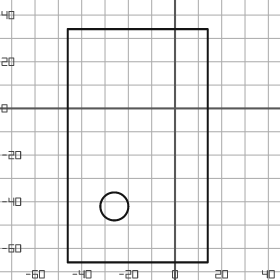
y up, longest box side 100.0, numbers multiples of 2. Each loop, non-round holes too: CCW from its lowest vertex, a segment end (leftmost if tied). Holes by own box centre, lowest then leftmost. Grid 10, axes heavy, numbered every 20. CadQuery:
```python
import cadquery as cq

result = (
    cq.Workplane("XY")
    .moveTo(-46.0, -66.0)
    .lineTo(14.0, -66.0)
    .lineTo(14.0, 34.0)
    .lineTo(-46.0, 34.0)
    .close()
    .moveTo(-26.0, -42.0)
    .circle(6.0)
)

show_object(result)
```